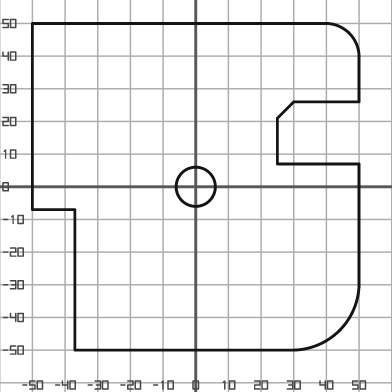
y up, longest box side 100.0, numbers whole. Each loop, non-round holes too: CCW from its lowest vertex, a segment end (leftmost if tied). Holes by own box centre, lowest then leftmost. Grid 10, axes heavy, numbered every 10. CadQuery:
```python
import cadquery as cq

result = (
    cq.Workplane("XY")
    .moveTo(-37.0, -50.0)
    .lineTo(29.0, -50.0)
    .threePointArc((44.0, -44.0), (50.0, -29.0))
    .lineTo(50.0, 7.0)
    .lineTo(25.0, 7.0)
    .lineTo(25.0, 21.0)
    .lineTo(30.0, 26.0)
    .lineTo(50.0, 26.0)
    .lineTo(50.0, 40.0)
    .threePointArc((47.0, 47.0), (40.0, 50.0))
    .lineTo(-50.0, 50.0)
    .lineTo(-50.0, -7.0)
    .lineTo(-37.0, -7.0)
    .close()
    .moveTo(0.0, 0.0)
    .circle(6.0)
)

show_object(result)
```